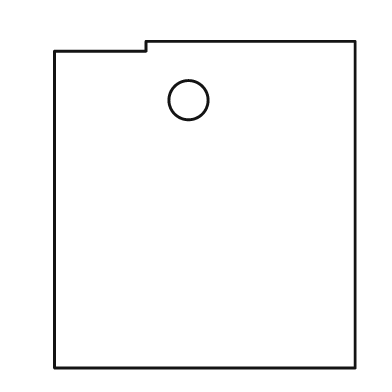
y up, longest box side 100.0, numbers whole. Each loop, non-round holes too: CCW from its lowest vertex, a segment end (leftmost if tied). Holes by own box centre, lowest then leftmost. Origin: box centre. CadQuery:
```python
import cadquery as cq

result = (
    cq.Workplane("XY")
    .moveTo(-46.0, -50.0)
    .lineTo(46.0, -50.0)
    .lineTo(46.0, 50.0)
    .lineTo(-18.0, 50.0)
    .lineTo(-18.0, 47.0)
    .lineTo(-46.0, 47.0)
    .close()
    .moveTo(-5.0, 32.0)
    .circle(6.0)
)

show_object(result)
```